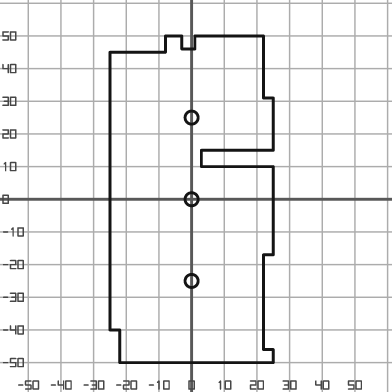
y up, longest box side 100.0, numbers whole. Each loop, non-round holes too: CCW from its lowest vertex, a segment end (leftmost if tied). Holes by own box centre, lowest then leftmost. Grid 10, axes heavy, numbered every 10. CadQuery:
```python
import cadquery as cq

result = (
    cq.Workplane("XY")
    .moveTo(-22.0, -50.0)
    .lineTo(25.0, -50.0)
    .lineTo(25.0, -46.0)
    .lineTo(22.0, -46.0)
    .lineTo(22.0, -17.0)
    .lineTo(25.0, -17.0)
    .lineTo(25.0, 10.0)
    .lineTo(3.0, 10.0)
    .lineTo(3.0, 15.0)
    .lineTo(25.0, 15.0)
    .lineTo(25.0, 31.0)
    .lineTo(22.0, 31.0)
    .lineTo(22.0, 50.0)
    .lineTo(1.0, 50.0)
    .lineTo(1.0, 46.0)
    .lineTo(-3.0, 46.0)
    .lineTo(-3.0, 50.0)
    .lineTo(-8.0, 50.0)
    .lineTo(-8.0, 45.0)
    .lineTo(-25.0, 45.0)
    .lineTo(-25.0, -40.0)
    .lineTo(-22.0, -40.0)
    .close()
    .moveTo(0.0, -25.0)
    .circle(2.0)
    .moveTo(0.0, 0.0)
    .circle(2.0)
    .moveTo(0.0, 25.0)
    .circle(2.0)
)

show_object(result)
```